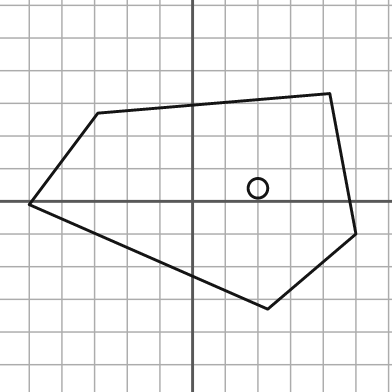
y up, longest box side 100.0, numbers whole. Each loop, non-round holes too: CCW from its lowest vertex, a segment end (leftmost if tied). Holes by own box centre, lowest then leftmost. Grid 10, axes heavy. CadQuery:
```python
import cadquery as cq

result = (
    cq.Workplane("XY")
    .moveTo(23.0, -33.0)
    .lineTo(50.0, -10.0)
    .lineTo(42.0, 33.0)
    .lineTo(-29.0, 27.0)
    .lineTo(-50.0, -1.0)
    .close()
    .moveTo(20.0, 4.0)
    .circle(3.0)
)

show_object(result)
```